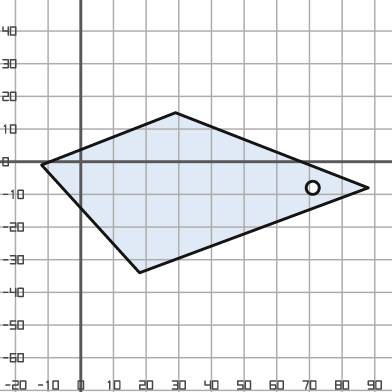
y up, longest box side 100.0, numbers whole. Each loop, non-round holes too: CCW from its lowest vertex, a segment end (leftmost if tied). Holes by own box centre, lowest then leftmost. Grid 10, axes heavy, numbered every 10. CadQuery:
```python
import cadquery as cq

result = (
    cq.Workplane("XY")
    .moveTo(18.0, -34.0)
    .lineTo(88.0, -8.0)
    .lineTo(29.0, 15.0)
    .lineTo(-12.0, -1.0)
    .close()
    .moveTo(71.0, -8.0)
    .circle(2.0)
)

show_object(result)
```